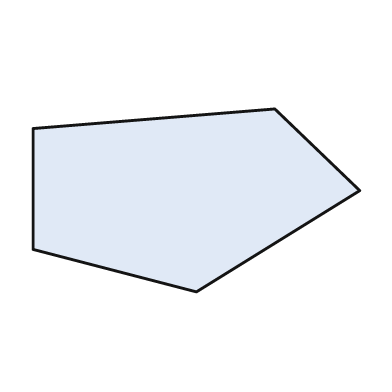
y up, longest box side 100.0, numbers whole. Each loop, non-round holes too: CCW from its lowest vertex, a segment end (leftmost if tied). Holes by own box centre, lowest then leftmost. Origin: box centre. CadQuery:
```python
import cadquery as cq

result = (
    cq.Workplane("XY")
    .moveTo(0.0, -28.0)
    .lineTo(50.0, 3.0)
    .lineTo(24.0, 28.0)
    .lineTo(-50.0, 22.0)
    .lineTo(-50.0, -15.0)
    .close()
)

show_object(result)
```